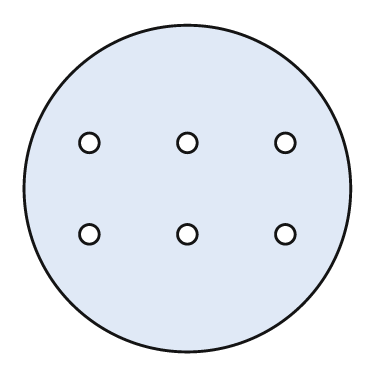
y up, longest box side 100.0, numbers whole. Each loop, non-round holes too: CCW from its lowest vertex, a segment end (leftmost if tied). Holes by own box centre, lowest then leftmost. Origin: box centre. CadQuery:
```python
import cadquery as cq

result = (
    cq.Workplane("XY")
    .moveTo(0.0, 0.0)
    .circle(50.0)
    .moveTo(-30.0, -14.0)
    .circle(3.0)
    .moveTo(0.0, -14.0)
    .circle(3.0)
    .moveTo(30.0, -14.0)
    .circle(3.0)
    .moveTo(-30.0, 14.0)
    .circle(3.0)
    .moveTo(0.0, 14.0)
    .circle(3.0)
    .moveTo(30.0, 14.0)
    .circle(3.0)
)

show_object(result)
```